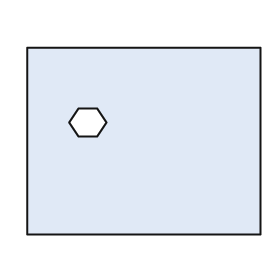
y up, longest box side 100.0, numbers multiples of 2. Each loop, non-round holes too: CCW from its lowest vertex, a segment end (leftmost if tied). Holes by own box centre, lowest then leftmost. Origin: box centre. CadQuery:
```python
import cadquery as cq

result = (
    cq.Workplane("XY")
    .moveTo(-50.0, -40.0)
    .lineTo(50.0, -40.0)
    .lineTo(50.0, 40.0)
    .lineTo(-50.0, 40.0)
    .close()
    .moveTo(-28.0, 2.0)
    .lineTo(-20.0, 2.0)
    .lineTo(-16.0, 8.0)
    .lineTo(-20.0, 14.0)
    .lineTo(-28.0, 14.0)
    .lineTo(-32.0, 8.0)
    .close()
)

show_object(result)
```